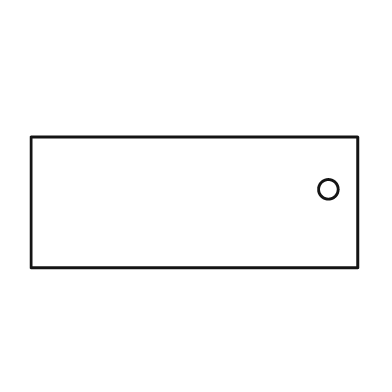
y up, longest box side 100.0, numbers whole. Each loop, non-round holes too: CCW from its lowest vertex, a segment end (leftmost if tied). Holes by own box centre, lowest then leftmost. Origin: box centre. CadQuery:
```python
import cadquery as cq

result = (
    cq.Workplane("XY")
    .moveTo(-50.0, -20.0)
    .lineTo(50.0, -20.0)
    .lineTo(50.0, 20.0)
    .lineTo(-50.0, 20.0)
    .close()
    .moveTo(41.0, 4.0)
    .circle(3.0)
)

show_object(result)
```